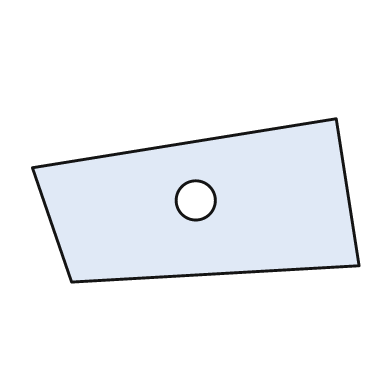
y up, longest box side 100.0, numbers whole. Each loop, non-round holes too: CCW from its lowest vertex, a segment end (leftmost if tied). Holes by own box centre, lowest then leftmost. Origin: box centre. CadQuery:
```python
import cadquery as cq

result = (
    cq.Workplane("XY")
    .moveTo(-38.0, -25.0)
    .lineTo(50.0, -20.0)
    .lineTo(43.0, 25.0)
    .lineTo(-50.0, 10.0)
    .close()
    .moveTo(0.0, 0.0)
    .circle(6.0)
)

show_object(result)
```